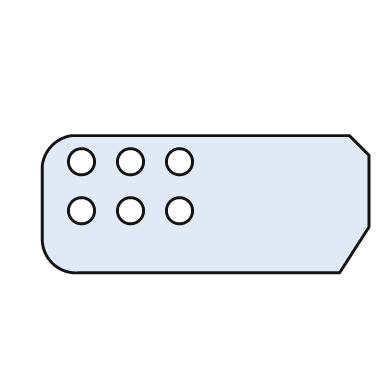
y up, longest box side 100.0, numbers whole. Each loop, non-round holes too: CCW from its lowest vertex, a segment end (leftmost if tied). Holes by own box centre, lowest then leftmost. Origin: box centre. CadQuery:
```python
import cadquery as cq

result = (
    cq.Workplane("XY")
    .moveTo(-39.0, -21.0)
    .lineTo(41.0, -21.0)
    .lineTo(50.0, -7.0)
    .lineTo(50.0, 15.0)
    .lineTo(44.0, 21.0)
    .lineTo(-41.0, 21.0)
    .threePointArc((-47.0, 18.0), (-50.0, 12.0))
    .lineTo(-50.0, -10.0)
    .threePointArc((-47.0, -18.0), (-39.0, -21.0))
    .close()
    .moveTo(-38.0, -2.0)
    .circle(4.0)
    .moveTo(-23.0, -2.0)
    .circle(4.0)
    .moveTo(-8.0, -2.0)
    .circle(4.0)
    .moveTo(-38.0, 13.0)
    .circle(4.0)
    .moveTo(-23.0, 13.0)
    .circle(4.0)
    .moveTo(-8.0, 13.0)
    .circle(4.0)
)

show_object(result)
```